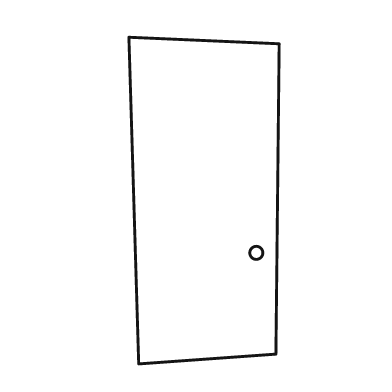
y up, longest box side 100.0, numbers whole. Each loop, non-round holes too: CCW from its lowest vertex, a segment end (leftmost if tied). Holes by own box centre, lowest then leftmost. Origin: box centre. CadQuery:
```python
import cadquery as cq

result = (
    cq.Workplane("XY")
    .moveTo(-20.0, -50.0)
    .lineTo(22.0, -47.0)
    .lineTo(23.0, 48.0)
    .lineTo(-23.0, 50.0)
    .close()
    .moveTo(16.0, -16.0)
    .circle(2.0)
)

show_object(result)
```